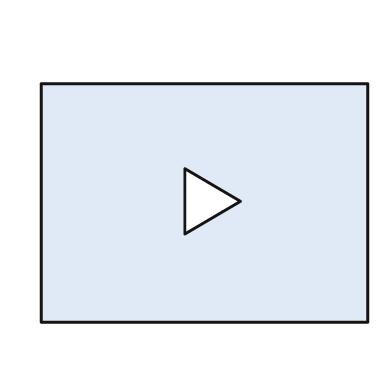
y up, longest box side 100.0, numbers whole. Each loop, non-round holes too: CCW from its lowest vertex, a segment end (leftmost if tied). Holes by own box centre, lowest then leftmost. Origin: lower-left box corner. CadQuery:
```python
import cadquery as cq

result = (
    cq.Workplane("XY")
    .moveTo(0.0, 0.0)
    .lineTo(100.0, 0.0)
    .lineTo(100.0, 73.0)
    .lineTo(0.0, 73.0)
    .close()
    .moveTo(44.0, 27.0)
    .lineTo(61.0, 37.0)
    .lineTo(44.0, 47.0)
    .close()
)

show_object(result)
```